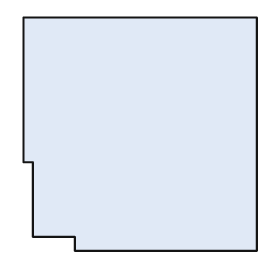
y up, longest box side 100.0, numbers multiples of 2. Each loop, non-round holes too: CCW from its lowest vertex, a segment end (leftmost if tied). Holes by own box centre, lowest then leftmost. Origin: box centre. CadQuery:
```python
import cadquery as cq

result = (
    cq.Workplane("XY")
    .moveTo(-28.0, -50.0)
    .lineTo(50.0, -50.0)
    .lineTo(50.0, 50.0)
    .lineTo(-50.0, 50.0)
    .lineTo(-50.0, -12.0)
    .lineTo(-46.0, -12.0)
    .lineTo(-46.0, -44.0)
    .lineTo(-28.0, -44.0)
    .close()
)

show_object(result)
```